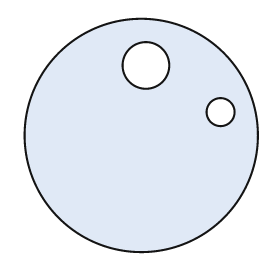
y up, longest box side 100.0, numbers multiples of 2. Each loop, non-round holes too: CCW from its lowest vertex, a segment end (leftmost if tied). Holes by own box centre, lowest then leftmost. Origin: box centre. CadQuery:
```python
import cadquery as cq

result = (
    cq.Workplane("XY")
    .moveTo(0.0, 0.0)
    .circle(50.0)
    .moveTo(34.0, 10.0)
    .circle(6.0)
    .moveTo(2.0, 30.0)
    .circle(10.0)
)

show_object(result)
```